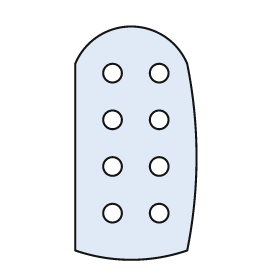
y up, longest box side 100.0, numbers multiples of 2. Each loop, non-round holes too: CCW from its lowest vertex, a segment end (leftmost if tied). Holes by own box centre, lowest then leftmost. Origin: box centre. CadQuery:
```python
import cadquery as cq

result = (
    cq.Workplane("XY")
    .moveTo(-26.0, -46.0)
    .threePointArc((-2.0, -50.0), (22.0, -46.0))
    .threePointArc((26.0, -6.0), (22.0, 34.0))
    .threePointArc((-2.0, 50.0), (-26.0, 34.0))
    .close()
    .moveTo(-10.0, -30.0)
    .circle(4.0)
    .moveTo(10.0, -30.0)
    .circle(4.0)
    .moveTo(-10.0, -10.0)
    .circle(4.0)
    .moveTo(10.0, -10.0)
    .circle(4.0)
    .moveTo(-10.0, 10.0)
    .circle(4.0)
    .moveTo(10.0, 10.0)
    .circle(4.0)
    .moveTo(-10.0, 30.0)
    .circle(4.0)
    .moveTo(10.0, 30.0)
    .circle(4.0)
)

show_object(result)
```